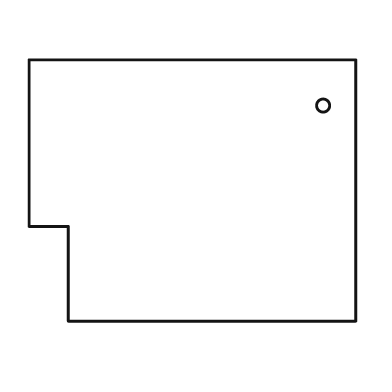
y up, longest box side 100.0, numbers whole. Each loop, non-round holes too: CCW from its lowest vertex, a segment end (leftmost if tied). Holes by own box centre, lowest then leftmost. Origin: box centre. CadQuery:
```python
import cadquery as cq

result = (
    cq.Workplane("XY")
    .moveTo(-38.0, -40.0)
    .lineTo(50.0, -40.0)
    .lineTo(50.0, 40.0)
    .lineTo(-50.0, 40.0)
    .lineTo(-50.0, -11.0)
    .lineTo(-38.0, -11.0)
    .close()
    .moveTo(40.0, 26.0)
    .circle(2.0)
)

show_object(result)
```